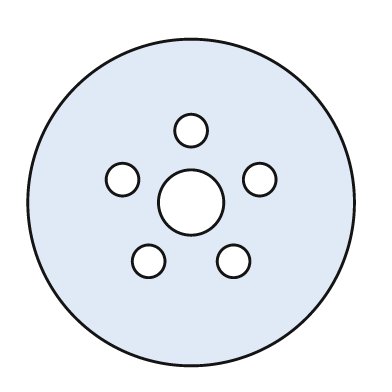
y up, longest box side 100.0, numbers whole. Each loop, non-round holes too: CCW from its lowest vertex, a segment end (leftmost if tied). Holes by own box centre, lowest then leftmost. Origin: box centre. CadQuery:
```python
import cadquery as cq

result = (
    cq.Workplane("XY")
    .moveTo(0.0, 0.0)
    .circle(50.0)
    .moveTo(-13.0, -18.0)
    .circle(5.0)
    .moveTo(13.0, -18.0)
    .circle(5.0)
    .moveTo(0.0, 0.0)
    .circle(10.0)
    .moveTo(-21.0, 7.0)
    .circle(5.0)
    .moveTo(21.0, 7.0)
    .circle(5.0)
    .moveTo(0.0, 22.0)
    .circle(5.0)
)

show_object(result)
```